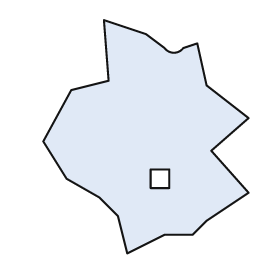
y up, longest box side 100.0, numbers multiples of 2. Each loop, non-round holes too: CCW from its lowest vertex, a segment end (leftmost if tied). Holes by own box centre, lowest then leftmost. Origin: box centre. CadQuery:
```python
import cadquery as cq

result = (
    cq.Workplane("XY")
    .moveTo(-8.0, -50.0)
    .lineTo(8.0, -42.0)
    .lineTo(20.0, -42.0)
    .lineTo(26.0, -36.0)
    .lineTo(44.0, -24.0)
    .lineTo(28.0, -6.0)
    .lineTo(44.0, 8.0)
    .lineTo(26.0, 22.0)
    .lineTo(22.0, 40.0)
    .lineTo(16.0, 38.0)
    .threePointArc((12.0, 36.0), (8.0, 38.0))
    .lineTo(0.0, 44.0)
    .lineTo(-18.0, 50.0)
    .lineTo(-16.0, 24.0)
    .lineTo(-32.0, 20.0)
    .lineTo(-44.0, -2.0)
    .lineTo(-34.0, -18.0)
    .lineTo(-20.0, -26.0)
    .lineTo(-12.0, -34.0)
    .close()
    .moveTo(2.0, -22.0)
    .lineTo(10.0, -22.0)
    .lineTo(10.0, -14.0)
    .lineTo(2.0, -14.0)
    .close()
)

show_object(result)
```